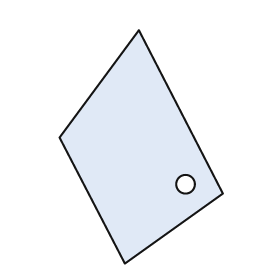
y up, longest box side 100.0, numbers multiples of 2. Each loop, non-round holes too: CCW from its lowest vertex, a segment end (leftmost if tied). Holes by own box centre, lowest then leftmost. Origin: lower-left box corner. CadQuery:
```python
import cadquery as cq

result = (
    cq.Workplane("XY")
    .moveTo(28.0, 0.0)
    .lineTo(70.0, 30.0)
    .lineTo(34.0, 100.0)
    .lineTo(0.0, 54.0)
    .close()
    .moveTo(54.0, 34.0)
    .circle(4.0)
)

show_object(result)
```